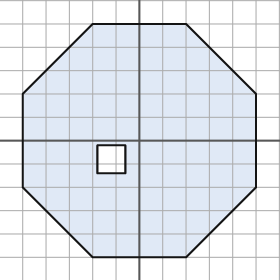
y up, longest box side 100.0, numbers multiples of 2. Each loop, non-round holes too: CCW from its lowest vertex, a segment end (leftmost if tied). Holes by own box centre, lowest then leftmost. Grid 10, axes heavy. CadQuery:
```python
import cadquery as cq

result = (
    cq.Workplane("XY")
    .moveTo(-20.0, -50.0)
    .lineTo(20.0, -50.0)
    .lineTo(50.0, -20.0)
    .lineTo(50.0, 20.0)
    .lineTo(20.0, 50.0)
    .lineTo(-20.0, 50.0)
    .lineTo(-50.0, 20.0)
    .lineTo(-50.0, -20.0)
    .close()
    .moveTo(-18.0, -14.0)
    .lineTo(-6.0, -14.0)
    .lineTo(-6.0, -2.0)
    .lineTo(-18.0, -2.0)
    .close()
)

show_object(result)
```